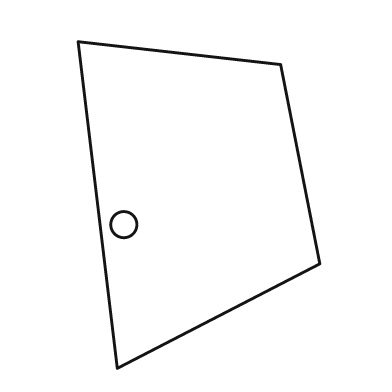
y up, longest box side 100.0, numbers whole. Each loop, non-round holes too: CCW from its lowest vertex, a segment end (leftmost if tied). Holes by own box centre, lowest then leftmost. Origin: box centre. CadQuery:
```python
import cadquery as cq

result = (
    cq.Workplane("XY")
    .moveTo(-25.0, -50.0)
    .lineTo(37.0, -18.0)
    .lineTo(25.0, 43.0)
    .lineTo(-37.0, 50.0)
    .close()
    .moveTo(-23.0, -6.0)
    .circle(4.0)
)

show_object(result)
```